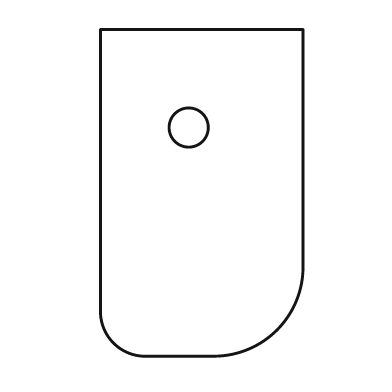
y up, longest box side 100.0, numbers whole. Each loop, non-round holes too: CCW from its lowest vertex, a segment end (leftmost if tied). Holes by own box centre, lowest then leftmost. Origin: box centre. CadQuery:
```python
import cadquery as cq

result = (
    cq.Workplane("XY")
    .moveTo(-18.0, -50.0)
    .lineTo(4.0, -50.0)
    .threePointArc((23.0, -42.0), (31.0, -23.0))
    .lineTo(31.0, 50.0)
    .lineTo(-31.0, 50.0)
    .lineTo(-31.0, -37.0)
    .threePointArc((-27.0, -46.0), (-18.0, -50.0))
    .close()
    .moveTo(-4.0, 20.0)
    .circle(6.0)
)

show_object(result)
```